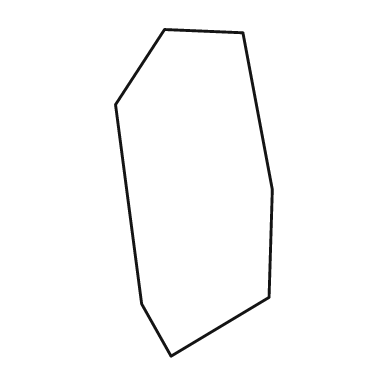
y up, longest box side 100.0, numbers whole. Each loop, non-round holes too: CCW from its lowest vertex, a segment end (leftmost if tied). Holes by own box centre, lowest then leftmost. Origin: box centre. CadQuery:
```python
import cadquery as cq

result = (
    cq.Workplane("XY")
    .moveTo(-7.0, -50.0)
    .lineTo(23.0, -32.0)
    .lineTo(24.0, 1.0)
    .lineTo(15.0, 49.0)
    .lineTo(-9.0, 50.0)
    .lineTo(-24.0, 27.0)
    .lineTo(-16.0, -34.0)
    .close()
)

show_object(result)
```